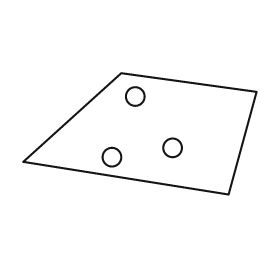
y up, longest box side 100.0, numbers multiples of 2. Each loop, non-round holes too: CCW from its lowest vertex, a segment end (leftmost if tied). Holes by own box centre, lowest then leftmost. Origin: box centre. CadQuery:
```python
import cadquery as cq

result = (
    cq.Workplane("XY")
    .moveTo(38.0, -26.0)
    .lineTo(50.0, 18.0)
    .lineTo(-8.0, 26.0)
    .lineTo(-50.0, -12.0)
    .close()
    .moveTo(-12.0, -10.0)
    .circle(4.0)
    .moveTo(14.0, -6.0)
    .circle(4.0)
    .moveTo(-2.0, 16.0)
    .circle(4.0)
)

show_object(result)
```